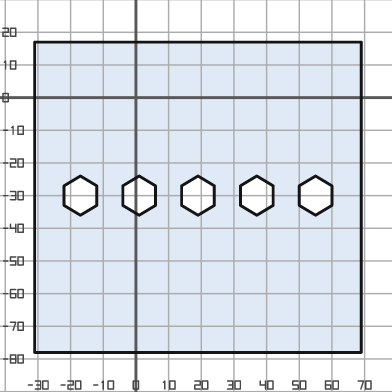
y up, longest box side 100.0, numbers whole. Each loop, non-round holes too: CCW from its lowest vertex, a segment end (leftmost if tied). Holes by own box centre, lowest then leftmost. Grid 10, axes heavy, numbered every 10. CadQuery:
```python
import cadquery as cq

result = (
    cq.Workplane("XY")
    .moveTo(-31.0, -78.0)
    .lineTo(69.0, -78.0)
    .lineTo(69.0, 17.0)
    .lineTo(-31.0, 17.0)
    .close()
    .moveTo(-17.0, -36.0)
    .lineTo(-12.0, -33.0)
    .lineTo(-12.0, -27.0)
    .lineTo(-17.0, -24.0)
    .lineTo(-22.0, -27.0)
    .lineTo(-22.0, -33.0)
    .close()
    .moveTo(1.0, -36.0)
    .lineTo(6.0, -33.0)
    .lineTo(6.0, -27.0)
    .lineTo(1.0, -24.0)
    .lineTo(-4.0, -27.0)
    .lineTo(-4.0, -33.0)
    .close()
    .moveTo(19.0, -36.0)
    .lineTo(24.0, -33.0)
    .lineTo(24.0, -27.0)
    .lineTo(19.0, -24.0)
    .lineTo(14.0, -27.0)
    .lineTo(14.0, -33.0)
    .close()
    .moveTo(37.0, -36.0)
    .lineTo(42.0, -33.0)
    .lineTo(42.0, -27.0)
    .lineTo(37.0, -24.0)
    .lineTo(32.0, -27.0)
    .lineTo(32.0, -33.0)
    .close()
    .moveTo(55.0, -36.0)
    .lineTo(60.0, -33.0)
    .lineTo(60.0, -27.0)
    .lineTo(55.0, -24.0)
    .lineTo(50.0, -27.0)
    .lineTo(50.0, -33.0)
    .close()
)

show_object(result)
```